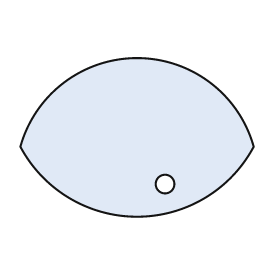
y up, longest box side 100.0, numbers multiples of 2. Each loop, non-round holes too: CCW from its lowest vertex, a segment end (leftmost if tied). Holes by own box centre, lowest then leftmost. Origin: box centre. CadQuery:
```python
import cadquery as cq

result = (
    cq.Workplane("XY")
    .moveTo(-50.0, -4.0)
    .threePointArc((0.0, -34.0), (50.0, -4.0))
    .threePointArc((0.0, 34.0), (-50.0, -4.0))
    .close()
    .moveTo(12.0, -20.0)
    .circle(4.0)
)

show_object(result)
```